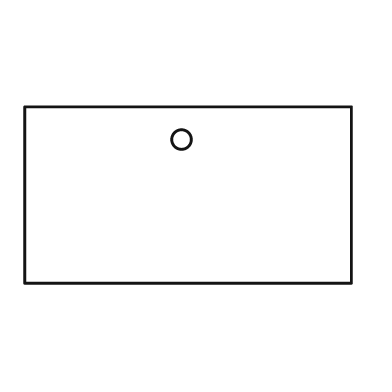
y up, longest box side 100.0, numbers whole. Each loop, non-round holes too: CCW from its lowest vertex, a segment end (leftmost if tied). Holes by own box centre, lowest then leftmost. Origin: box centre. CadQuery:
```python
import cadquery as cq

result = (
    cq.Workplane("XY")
    .moveTo(-50.0, -27.0)
    .lineTo(50.0, -27.0)
    .lineTo(50.0, 27.0)
    .lineTo(-50.0, 27.0)
    .close()
    .moveTo(-2.0, 17.0)
    .circle(3.0)
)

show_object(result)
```